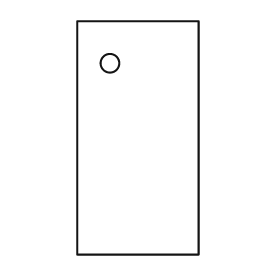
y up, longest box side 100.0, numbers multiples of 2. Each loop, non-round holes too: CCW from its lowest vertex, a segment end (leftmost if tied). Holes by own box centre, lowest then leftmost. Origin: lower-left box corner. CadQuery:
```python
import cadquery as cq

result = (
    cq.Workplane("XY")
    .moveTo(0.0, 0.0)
    .lineTo(52.0, 0.0)
    .lineTo(52.0, 100.0)
    .lineTo(0.0, 100.0)
    .close()
    .moveTo(14.0, 82.0)
    .circle(4.0)
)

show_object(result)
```